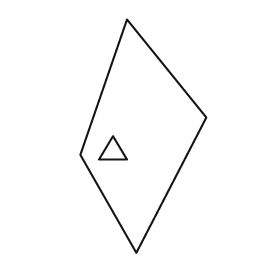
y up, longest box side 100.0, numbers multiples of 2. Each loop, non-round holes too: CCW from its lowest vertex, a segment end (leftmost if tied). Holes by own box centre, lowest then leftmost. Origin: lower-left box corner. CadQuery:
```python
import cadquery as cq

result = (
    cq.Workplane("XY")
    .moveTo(24.0, 0.0)
    .lineTo(54.0, 58.0)
    .lineTo(20.0, 100.0)
    .lineTo(0.0, 42.0)
    .close()
    .moveTo(8.0, 40.0)
    .lineTo(20.0, 40.0)
    .lineTo(14.0, 50.0)
    .close()
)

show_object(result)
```